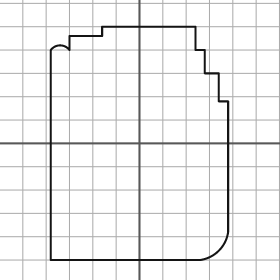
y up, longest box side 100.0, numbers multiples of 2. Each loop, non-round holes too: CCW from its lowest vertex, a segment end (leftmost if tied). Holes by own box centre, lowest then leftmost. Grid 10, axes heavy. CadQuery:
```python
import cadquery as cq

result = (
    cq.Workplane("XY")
    .moveTo(-38.0, -50.0)
    .lineTo(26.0, -50.0)
    .threePointArc((34.0, -46.0), (38.0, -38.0))
    .lineTo(38.0, 18.0)
    .lineTo(34.0, 18.0)
    .lineTo(34.0, 30.0)
    .lineTo(28.0, 30.0)
    .lineTo(28.0, 40.0)
    .lineTo(24.0, 40.0)
    .lineTo(24.0, 50.0)
    .lineTo(-16.0, 50.0)
    .lineTo(-16.0, 46.0)
    .lineTo(-30.0, 46.0)
    .lineTo(-30.0, 40.0)
    .threePointArc((-34.0, 42.0), (-38.0, 40.0))
    .close()
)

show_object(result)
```